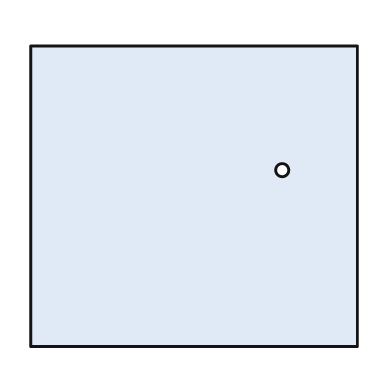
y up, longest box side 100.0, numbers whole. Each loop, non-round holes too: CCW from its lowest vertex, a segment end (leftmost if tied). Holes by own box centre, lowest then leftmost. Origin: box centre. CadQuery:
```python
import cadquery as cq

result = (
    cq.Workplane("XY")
    .moveTo(-50.0, -46.0)
    .lineTo(50.0, -46.0)
    .lineTo(50.0, 46.0)
    .lineTo(-50.0, 46.0)
    .close()
    .moveTo(27.0, 8.0)
    .circle(2.0)
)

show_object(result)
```